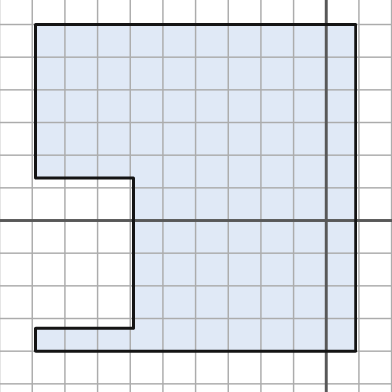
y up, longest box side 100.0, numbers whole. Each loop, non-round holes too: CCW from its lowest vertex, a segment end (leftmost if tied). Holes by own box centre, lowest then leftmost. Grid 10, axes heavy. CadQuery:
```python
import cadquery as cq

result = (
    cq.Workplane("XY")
    .moveTo(-89.0, -40.0)
    .lineTo(9.0, -40.0)
    .lineTo(9.0, 60.0)
    .lineTo(-89.0, 60.0)
    .lineTo(-89.0, 13.0)
    .lineTo(-59.0, 13.0)
    .lineTo(-59.0, -33.0)
    .lineTo(-89.0, -33.0)
    .close()
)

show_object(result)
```